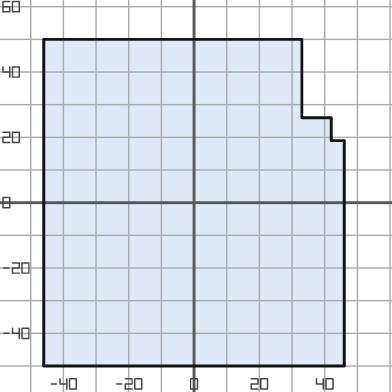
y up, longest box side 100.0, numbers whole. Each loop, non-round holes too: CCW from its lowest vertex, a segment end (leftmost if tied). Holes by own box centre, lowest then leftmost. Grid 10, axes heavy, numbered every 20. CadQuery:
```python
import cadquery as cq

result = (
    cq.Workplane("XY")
    .moveTo(-46.0, -50.0)
    .lineTo(46.0, -50.0)
    .lineTo(46.0, 19.0)
    .lineTo(42.0, 19.0)
    .lineTo(42.0, 26.0)
    .lineTo(33.0, 26.0)
    .lineTo(33.0, 50.0)
    .lineTo(-46.0, 50.0)
    .close()
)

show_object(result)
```